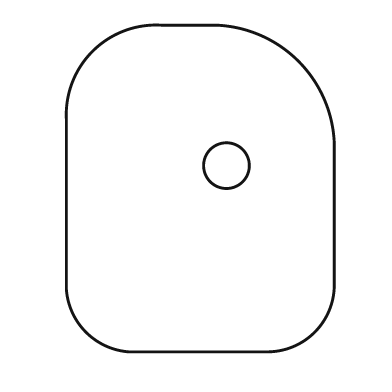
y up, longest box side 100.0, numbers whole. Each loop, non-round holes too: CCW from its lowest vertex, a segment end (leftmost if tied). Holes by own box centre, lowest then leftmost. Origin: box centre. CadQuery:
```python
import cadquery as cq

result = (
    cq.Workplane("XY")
    .moveTo(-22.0, -50.0)
    .lineTo(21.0, -50.0)
    .threePointArc((35.0, -44.0), (41.0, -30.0))
    .lineTo(41.0, 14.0)
    .threePointArc((30.0, 39.0), (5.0, 50.0))
    .lineTo(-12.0, 50.0)
    .threePointArc((-33.0, 42.0), (-41.0, 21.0))
    .lineTo(-41.0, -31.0)
    .threePointArc((-35.0, -44.0), (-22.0, -50.0))
    .close()
    .moveTo(8.0, 7.0)
    .circle(7.0)
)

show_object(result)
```